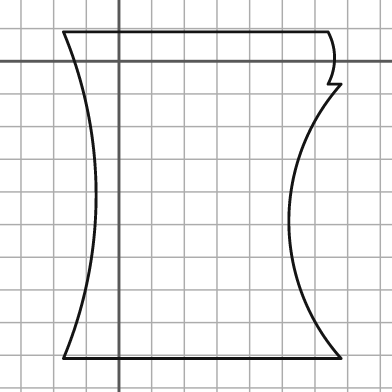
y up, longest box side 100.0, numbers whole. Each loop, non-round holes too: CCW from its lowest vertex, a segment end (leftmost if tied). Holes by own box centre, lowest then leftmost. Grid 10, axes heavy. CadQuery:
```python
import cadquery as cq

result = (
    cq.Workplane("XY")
    .moveTo(-17.0, -91.0)
    .lineTo(68.0, -91.0)
    .threePointArc((52.0, -49.0), (68.0, -7.0))
    .lineTo(64.0, -7.0)
    .threePointArc((66.0, 1.0), (64.0, 9.0))
    .lineTo(-17.0, 9.0)
    .threePointArc((-7.0, -41.0), (-17.0, -91.0))
    .close()
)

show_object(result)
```